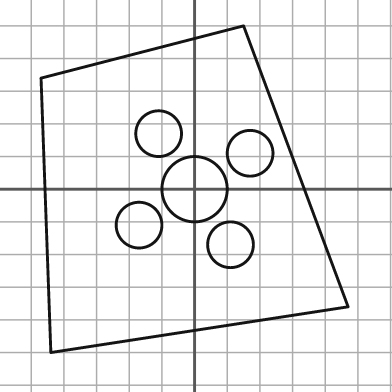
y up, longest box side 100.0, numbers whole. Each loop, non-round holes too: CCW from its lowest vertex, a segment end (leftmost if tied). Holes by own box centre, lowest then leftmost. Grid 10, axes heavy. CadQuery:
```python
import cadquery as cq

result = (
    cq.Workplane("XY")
    .moveTo(-44.0, -50.0)
    .lineTo(47.0, -36.0)
    .lineTo(15.0, 50.0)
    .lineTo(-47.0, 34.0)
    .close()
    .moveTo(11.0, -17.0)
    .circle(7.0)
    .moveTo(-17.0, -11.0)
    .circle(7.0)
    .moveTo(0.0, 0.0)
    .circle(10.0)
    .moveTo(17.0, 11.0)
    .circle(7.0)
    .moveTo(-11.0, 17.0)
    .circle(7.0)
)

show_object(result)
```